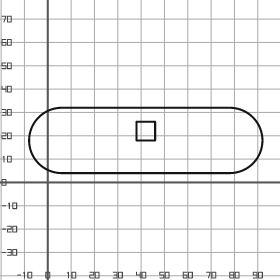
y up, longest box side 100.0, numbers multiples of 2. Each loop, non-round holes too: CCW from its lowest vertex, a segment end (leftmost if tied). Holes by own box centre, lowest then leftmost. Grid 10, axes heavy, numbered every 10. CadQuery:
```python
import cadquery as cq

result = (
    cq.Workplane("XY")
    .moveTo(6.0, 4.0)
    .lineTo(78.0, 4.0)
    .threePointArc((92.0, 18.0), (78.0, 32.0))
    .lineTo(6.0, 32.0)
    .threePointArc((-8.0, 18.0), (6.0, 4.0))
    .close()
    .moveTo(38.0, 18.0)
    .lineTo(46.0, 18.0)
    .lineTo(46.0, 26.0)
    .lineTo(38.0, 26.0)
    .close()
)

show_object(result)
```